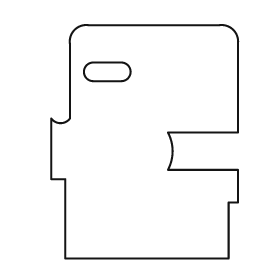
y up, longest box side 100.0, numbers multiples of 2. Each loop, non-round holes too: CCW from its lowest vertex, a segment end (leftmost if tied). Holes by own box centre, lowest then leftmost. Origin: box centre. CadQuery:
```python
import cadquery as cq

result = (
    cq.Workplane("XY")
    .moveTo(-34.0, -50.0)
    .lineTo(36.0, -50.0)
    .lineTo(36.0, -26.0)
    .lineTo(40.0, -26.0)
    .lineTo(40.0, -12.0)
    .lineTo(10.0, -12.0)
    .threePointArc((12.0, -4.0), (10.0, 4.0))
    .lineTo(40.0, 4.0)
    .lineTo(40.0, 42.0)
    .threePointArc((38.0, 48.0), (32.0, 50.0))
    .lineTo(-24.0, 50.0)
    .threePointArc((-30.0, 48.0), (-32.0, 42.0))
    .lineTo(-32.0, 10.0)
    .threePointArc((-36.0, 8.0), (-40.0, 10.0))
    .lineTo(-40.0, -16.0)
    .lineTo(-34.0, -16.0)
    .close()
    .moveTo(-22.0, 26.0)
    .lineTo(-10.0, 26.0)
    .threePointArc((-6.0, 30.0), (-10.0, 34.0))
    .lineTo(-22.0, 34.0)
    .threePointArc((-26.0, 30.0), (-22.0, 26.0))
    .close()
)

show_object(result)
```